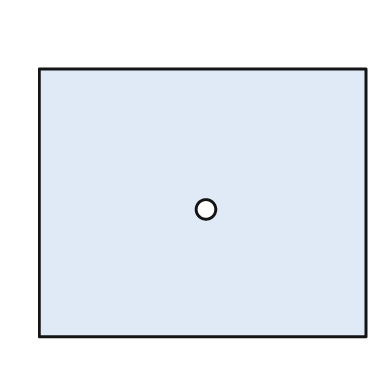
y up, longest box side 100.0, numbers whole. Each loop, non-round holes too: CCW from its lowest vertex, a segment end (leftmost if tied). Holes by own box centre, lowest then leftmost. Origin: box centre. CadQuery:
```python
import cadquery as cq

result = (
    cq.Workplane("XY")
    .moveTo(-50.0, -41.0)
    .lineTo(50.0, -41.0)
    .lineTo(50.0, 41.0)
    .lineTo(-50.0, 41.0)
    .close()
    .moveTo(1.0, -2.0)
    .circle(3.0)
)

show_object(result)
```